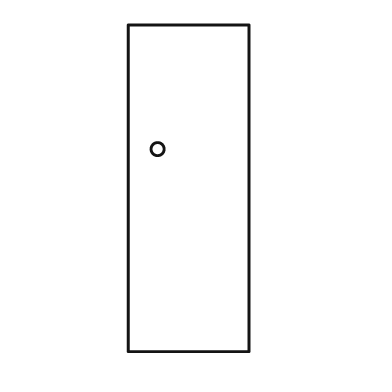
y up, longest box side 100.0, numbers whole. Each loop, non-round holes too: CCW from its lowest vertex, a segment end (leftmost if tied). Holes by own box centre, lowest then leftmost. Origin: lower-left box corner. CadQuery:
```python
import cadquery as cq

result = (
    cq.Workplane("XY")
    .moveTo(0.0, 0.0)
    .lineTo(37.0, 0.0)
    .lineTo(37.0, 100.0)
    .lineTo(0.0, 100.0)
    .close()
    .moveTo(9.0, 62.0)
    .circle(2.0)
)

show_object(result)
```